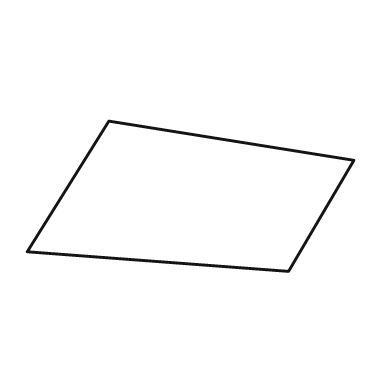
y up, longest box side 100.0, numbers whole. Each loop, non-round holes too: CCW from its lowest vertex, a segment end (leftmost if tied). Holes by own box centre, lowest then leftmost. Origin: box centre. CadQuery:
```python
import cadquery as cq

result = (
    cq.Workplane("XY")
    .moveTo(30.0, -23.0)
    .lineTo(50.0, 11.0)
    .lineTo(-25.0, 23.0)
    .lineTo(-50.0, -17.0)
    .close()
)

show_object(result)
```